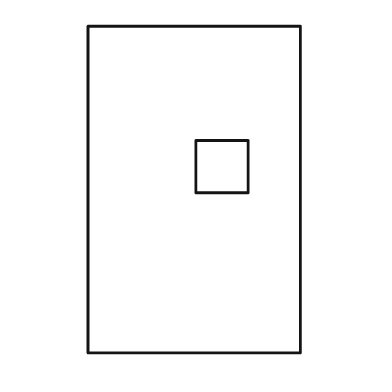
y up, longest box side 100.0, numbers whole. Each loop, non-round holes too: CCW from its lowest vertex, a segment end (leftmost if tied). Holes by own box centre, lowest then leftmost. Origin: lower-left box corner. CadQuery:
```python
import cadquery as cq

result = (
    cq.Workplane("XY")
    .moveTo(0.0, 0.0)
    .lineTo(65.0, 0.0)
    .lineTo(65.0, 100.0)
    .lineTo(0.0, 100.0)
    .close()
    .moveTo(33.0, 49.0)
    .lineTo(49.0, 49.0)
    .lineTo(49.0, 65.0)
    .lineTo(33.0, 65.0)
    .close()
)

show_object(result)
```